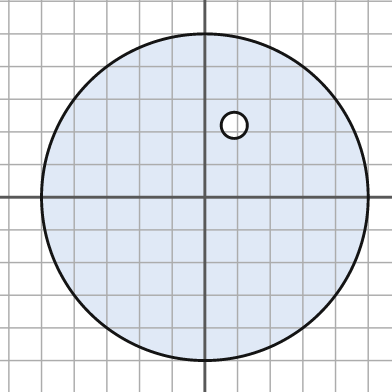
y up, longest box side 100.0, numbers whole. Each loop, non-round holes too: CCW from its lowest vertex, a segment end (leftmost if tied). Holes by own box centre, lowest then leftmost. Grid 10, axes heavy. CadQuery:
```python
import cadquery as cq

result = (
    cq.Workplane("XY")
    .moveTo(0.0, 0.0)
    .circle(50.0)
    .moveTo(9.0, 22.0)
    .circle(4.0)
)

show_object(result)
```